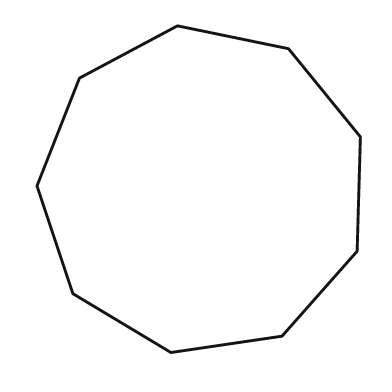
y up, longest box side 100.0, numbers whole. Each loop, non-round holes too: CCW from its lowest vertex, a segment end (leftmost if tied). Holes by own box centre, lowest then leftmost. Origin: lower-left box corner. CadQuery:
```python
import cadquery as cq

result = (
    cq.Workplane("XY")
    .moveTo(41.0, 0.0)
    .lineTo(75.0, 5.0)
    .lineTo(98.0, 31.0)
    .lineTo(99.0, 66.0)
    .lineTo(77.0, 93.0)
    .lineTo(43.0, 100.0)
    .lineTo(13.0, 84.0)
    .lineTo(0.0, 51.0)
    .lineTo(11.0, 18.0)
    .close()
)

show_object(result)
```